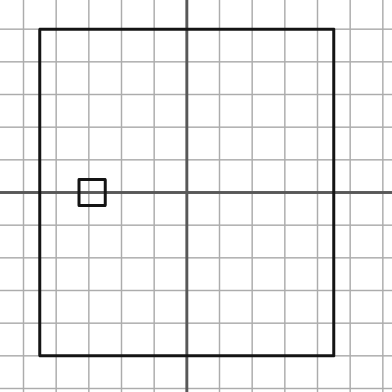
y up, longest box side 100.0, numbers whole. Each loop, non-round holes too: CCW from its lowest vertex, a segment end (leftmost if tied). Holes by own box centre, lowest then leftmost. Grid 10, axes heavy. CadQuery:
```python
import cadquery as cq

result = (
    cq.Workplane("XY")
    .moveTo(-45.0, -50.0)
    .lineTo(45.0, -50.0)
    .lineTo(45.0, 50.0)
    .lineTo(-45.0, 50.0)
    .close()
    .moveTo(-33.0, -4.0)
    .lineTo(-25.0, -4.0)
    .lineTo(-25.0, 4.0)
    .lineTo(-33.0, 4.0)
    .close()
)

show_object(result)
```